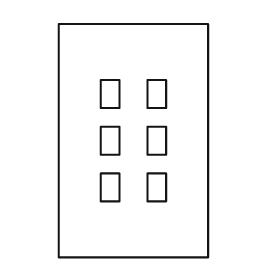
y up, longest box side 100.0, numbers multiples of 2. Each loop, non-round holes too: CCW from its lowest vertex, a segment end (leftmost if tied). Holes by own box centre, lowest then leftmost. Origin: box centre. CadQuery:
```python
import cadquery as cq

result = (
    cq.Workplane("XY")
    .moveTo(-32.0, -50.0)
    .lineTo(32.0, -50.0)
    .lineTo(32.0, 50.0)
    .lineTo(-32.0, 50.0)
    .close()
    .moveTo(-14.0, -26.0)
    .lineTo(-6.0, -26.0)
    .lineTo(-6.0, -14.0)
    .lineTo(-14.0, -14.0)
    .close()
    .moveTo(6.0, -26.0)
    .lineTo(14.0, -26.0)
    .lineTo(14.0, -14.0)
    .lineTo(6.0, -14.0)
    .close()
    .moveTo(-14.0, -6.0)
    .lineTo(-6.0, -6.0)
    .lineTo(-6.0, 6.0)
    .lineTo(-14.0, 6.0)
    .close()
    .moveTo(6.0, -6.0)
    .lineTo(14.0, -6.0)
    .lineTo(14.0, 6.0)
    .lineTo(6.0, 6.0)
    .close()
    .moveTo(-14.0, 14.0)
    .lineTo(-6.0, 14.0)
    .lineTo(-6.0, 26.0)
    .lineTo(-14.0, 26.0)
    .close()
    .moveTo(6.0, 14.0)
    .lineTo(14.0, 14.0)
    .lineTo(14.0, 26.0)
    .lineTo(6.0, 26.0)
    .close()
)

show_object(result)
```